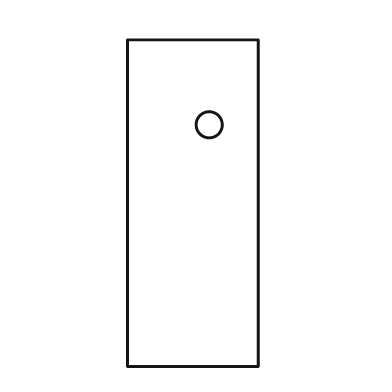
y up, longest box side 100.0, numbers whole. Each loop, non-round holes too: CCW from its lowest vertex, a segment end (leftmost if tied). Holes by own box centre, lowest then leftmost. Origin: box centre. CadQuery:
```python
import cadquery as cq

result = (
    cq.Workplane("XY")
    .moveTo(-20.0, -50.0)
    .lineTo(20.0, -50.0)
    .lineTo(20.0, 50.0)
    .lineTo(-20.0, 50.0)
    .close()
    .moveTo(5.0, 24.0)
    .circle(4.0)
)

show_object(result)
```